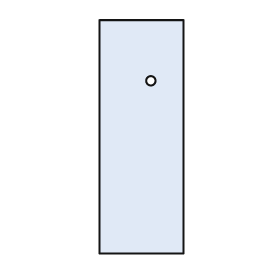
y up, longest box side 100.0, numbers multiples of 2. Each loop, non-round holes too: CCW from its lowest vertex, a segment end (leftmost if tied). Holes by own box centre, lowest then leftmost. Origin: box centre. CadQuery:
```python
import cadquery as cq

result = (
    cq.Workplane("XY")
    .moveTo(-18.0, -50.0)
    .lineTo(18.0, -50.0)
    .lineTo(18.0, 50.0)
    .lineTo(-18.0, 50.0)
    .close()
    .moveTo(4.0, 24.0)
    .circle(2.0)
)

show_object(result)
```